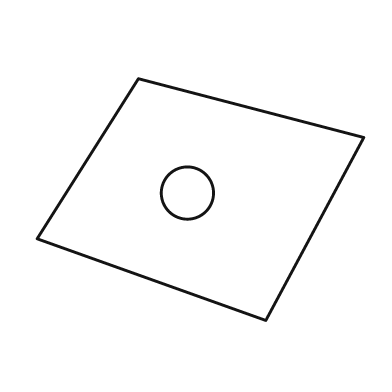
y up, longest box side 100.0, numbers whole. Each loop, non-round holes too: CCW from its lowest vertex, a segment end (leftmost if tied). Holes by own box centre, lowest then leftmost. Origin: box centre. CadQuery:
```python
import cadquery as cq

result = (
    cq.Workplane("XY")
    .moveTo(20.0, -37.0)
    .lineTo(50.0, 19.0)
    .lineTo(-19.0, 37.0)
    .lineTo(-50.0, -12.0)
    .close()
    .moveTo(-4.0, 2.0)
    .circle(8.0)
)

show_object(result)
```